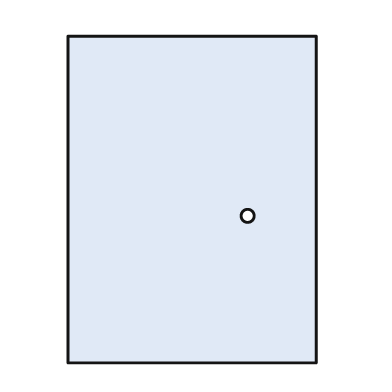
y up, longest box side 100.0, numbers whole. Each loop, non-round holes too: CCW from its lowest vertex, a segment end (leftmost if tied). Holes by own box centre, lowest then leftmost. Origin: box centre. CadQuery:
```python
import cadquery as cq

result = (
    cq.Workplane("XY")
    .moveTo(-38.0, -50.0)
    .lineTo(38.0, -50.0)
    .lineTo(38.0, 50.0)
    .lineTo(-38.0, 50.0)
    .close()
    .moveTo(17.0, -5.0)
    .circle(2.0)
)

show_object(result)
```